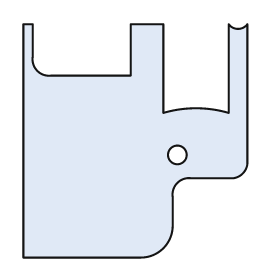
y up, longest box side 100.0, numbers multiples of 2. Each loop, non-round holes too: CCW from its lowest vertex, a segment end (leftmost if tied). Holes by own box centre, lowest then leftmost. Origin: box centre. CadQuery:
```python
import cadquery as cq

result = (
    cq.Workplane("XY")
    .moveTo(-48.0, -50.0)
    .lineTo(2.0, -50.0)
    .threePointArc((12.0, -46.0), (16.0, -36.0))
    .lineTo(16.0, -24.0)
    .threePointArc((18.0, -18.0), (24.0, -16.0))
    .lineTo(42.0, -16.0)
    .threePointArc((46.0, -14.0), (48.0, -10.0))
    .lineTo(48.0, 50.0)
    .threePointArc((44.0, 48.0), (40.0, 50.0))
    .lineTo(40.0, 12.0)
    .threePointArc((26.0, 14.0), (12.0, 12.0))
    .lineTo(12.0, 50.0)
    .lineTo(-2.0, 50.0)
    .lineTo(-2.0, 28.0)
    .lineTo(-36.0, 28.0)
    .threePointArc((-42.0, 30.0), (-44.0, 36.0))
    .lineTo(-44.0, 50.0)
    .lineTo(-48.0, 50.0)
    .close()
    .moveTo(18.0, -6.0)
    .circle(4.0)
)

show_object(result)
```